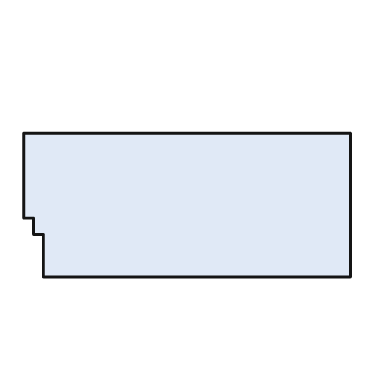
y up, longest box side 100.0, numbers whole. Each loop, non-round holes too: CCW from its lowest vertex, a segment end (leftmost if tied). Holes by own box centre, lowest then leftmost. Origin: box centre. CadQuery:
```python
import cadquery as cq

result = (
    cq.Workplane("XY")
    .moveTo(-44.0, -22.0)
    .lineTo(50.0, -22.0)
    .lineTo(50.0, 22.0)
    .lineTo(-50.0, 22.0)
    .lineTo(-50.0, -4.0)
    .lineTo(-47.0, -4.0)
    .lineTo(-47.0, -9.0)
    .lineTo(-44.0, -9.0)
    .close()
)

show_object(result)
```